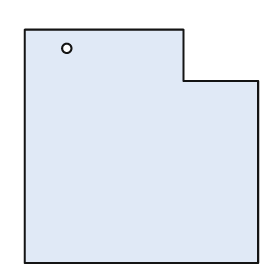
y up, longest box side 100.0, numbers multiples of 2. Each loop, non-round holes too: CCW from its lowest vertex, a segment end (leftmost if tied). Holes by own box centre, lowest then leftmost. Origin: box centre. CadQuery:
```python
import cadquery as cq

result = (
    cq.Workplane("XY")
    .moveTo(-50.0, -50.0)
    .lineTo(50.0, -50.0)
    .lineTo(50.0, 28.0)
    .lineTo(18.0, 28.0)
    .lineTo(18.0, 50.0)
    .lineTo(-50.0, 50.0)
    .close()
    .moveTo(-32.0, 42.0)
    .circle(2.0)
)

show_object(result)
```